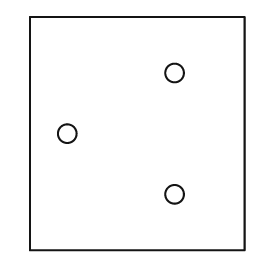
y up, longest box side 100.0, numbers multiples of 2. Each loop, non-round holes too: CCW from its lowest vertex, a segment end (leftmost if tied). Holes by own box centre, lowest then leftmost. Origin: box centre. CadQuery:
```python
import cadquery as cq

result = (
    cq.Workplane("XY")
    .moveTo(-46.0, -50.0)
    .lineTo(46.0, -50.0)
    .lineTo(46.0, 50.0)
    .lineTo(-46.0, 50.0)
    .close()
    .moveTo(16.0, -26.0)
    .circle(4.0)
    .moveTo(-30.0, 0.0)
    .circle(4.0)
    .moveTo(16.0, 26.0)
    .circle(4.0)
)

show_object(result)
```